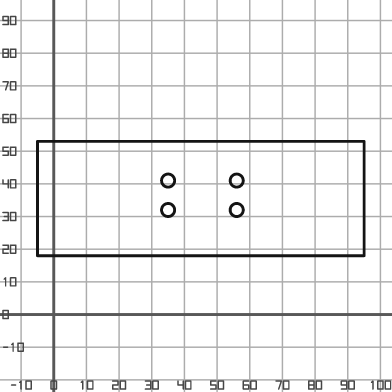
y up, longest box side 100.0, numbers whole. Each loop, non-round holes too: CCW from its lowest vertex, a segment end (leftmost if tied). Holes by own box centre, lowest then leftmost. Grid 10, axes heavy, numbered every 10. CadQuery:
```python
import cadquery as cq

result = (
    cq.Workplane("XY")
    .moveTo(-5.0, 18.0)
    .lineTo(95.0, 18.0)
    .lineTo(95.0, 53.0)
    .lineTo(-5.0, 53.0)
    .close()
    .moveTo(35.0, 32.0)
    .circle(2.0)
    .moveTo(56.0, 32.0)
    .circle(2.0)
    .moveTo(35.0, 41.0)
    .circle(2.0)
    .moveTo(56.0, 41.0)
    .circle(2.0)
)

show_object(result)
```